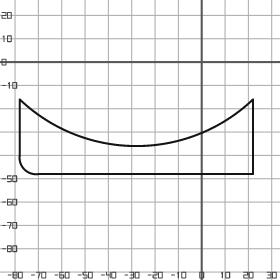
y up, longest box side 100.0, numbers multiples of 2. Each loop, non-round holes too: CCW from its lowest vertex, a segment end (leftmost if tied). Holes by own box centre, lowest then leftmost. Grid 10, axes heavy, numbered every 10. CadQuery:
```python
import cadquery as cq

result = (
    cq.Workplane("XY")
    .moveTo(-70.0, -48.0)
    .lineTo(22.0, -48.0)
    .lineTo(22.0, -16.0)
    .threePointArc((-28.0, -36.0), (-78.0, -16.0))
    .lineTo(-78.0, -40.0)
    .threePointArc((-76.0, -46.0), (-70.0, -48.0))
    .close()
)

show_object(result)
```